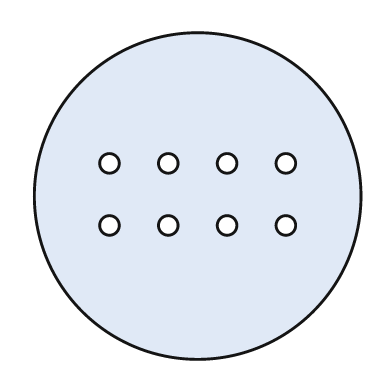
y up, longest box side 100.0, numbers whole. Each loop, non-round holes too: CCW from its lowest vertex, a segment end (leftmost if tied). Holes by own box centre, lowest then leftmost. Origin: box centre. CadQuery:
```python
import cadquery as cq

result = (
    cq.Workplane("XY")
    .moveTo(0.0, 0.0)
    .circle(50.0)
    .moveTo(-27.0, -9.0)
    .circle(3.0)
    .moveTo(-9.0, -9.0)
    .circle(3.0)
    .moveTo(9.0, -9.0)
    .circle(3.0)
    .moveTo(27.0, -9.0)
    .circle(3.0)
    .moveTo(-27.0, 10.0)
    .circle(3.0)
    .moveTo(-9.0, 10.0)
    .circle(3.0)
    .moveTo(9.0, 10.0)
    .circle(3.0)
    .moveTo(27.0, 10.0)
    .circle(3.0)
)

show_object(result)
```